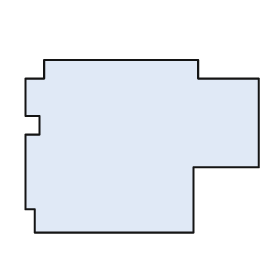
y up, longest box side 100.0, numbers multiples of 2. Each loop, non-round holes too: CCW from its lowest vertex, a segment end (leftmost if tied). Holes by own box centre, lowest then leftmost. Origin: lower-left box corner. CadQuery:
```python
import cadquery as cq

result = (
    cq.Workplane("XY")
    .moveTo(4.0, 0.0)
    .lineTo(72.0, 0.0)
    .lineTo(72.0, 28.0)
    .lineTo(100.0, 28.0)
    .lineTo(100.0, 66.0)
    .lineTo(74.0, 66.0)
    .lineTo(74.0, 74.0)
    .lineTo(8.0, 74.0)
    .lineTo(8.0, 66.0)
    .lineTo(0.0, 66.0)
    .lineTo(0.0, 50.0)
    .lineTo(6.0, 50.0)
    .lineTo(6.0, 42.0)
    .lineTo(0.0, 42.0)
    .lineTo(0.0, 10.0)
    .lineTo(4.0, 10.0)
    .close()
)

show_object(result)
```